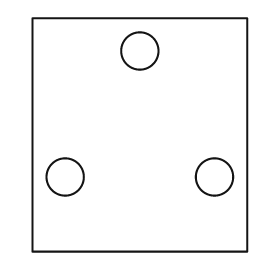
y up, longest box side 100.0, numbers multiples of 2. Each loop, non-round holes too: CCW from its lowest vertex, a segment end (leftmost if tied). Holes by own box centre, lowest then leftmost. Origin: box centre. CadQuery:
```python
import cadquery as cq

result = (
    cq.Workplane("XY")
    .moveTo(-46.0, -50.0)
    .lineTo(46.0, -50.0)
    .lineTo(46.0, 50.0)
    .lineTo(-46.0, 50.0)
    .close()
    .moveTo(-32.0, -18.0)
    .circle(8.0)
    .moveTo(32.0, -18.0)
    .circle(8.0)
    .moveTo(0.0, 36.0)
    .circle(8.0)
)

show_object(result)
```